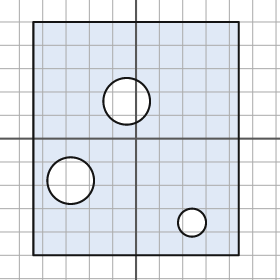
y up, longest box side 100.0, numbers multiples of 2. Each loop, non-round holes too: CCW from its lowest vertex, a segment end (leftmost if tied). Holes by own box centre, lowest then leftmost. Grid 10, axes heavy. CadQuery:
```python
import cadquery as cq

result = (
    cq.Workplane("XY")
    .moveTo(-44.0, -50.0)
    .lineTo(44.0, -50.0)
    .lineTo(44.0, 50.0)
    .lineTo(-44.0, 50.0)
    .close()
    .moveTo(24.0, -36.0)
    .circle(6.0)
    .moveTo(-28.0, -18.0)
    .circle(10.0)
    .moveTo(-4.0, 16.0)
    .circle(10.0)
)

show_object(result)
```